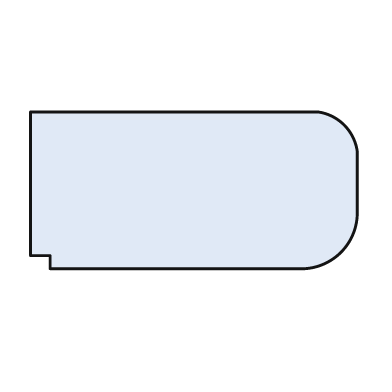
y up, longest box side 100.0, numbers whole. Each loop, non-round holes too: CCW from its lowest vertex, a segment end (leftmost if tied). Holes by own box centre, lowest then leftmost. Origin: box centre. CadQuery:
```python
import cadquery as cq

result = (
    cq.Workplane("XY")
    .moveTo(-44.0, -24.0)
    .lineTo(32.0, -24.0)
    .threePointArc((45.0, -19.0), (50.0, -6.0))
    .lineTo(50.0, 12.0)
    .threePointArc((46.0, 20.0), (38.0, 24.0))
    .lineTo(-50.0, 24.0)
    .lineTo(-50.0, -20.0)
    .lineTo(-44.0, -20.0)
    .close()
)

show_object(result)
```